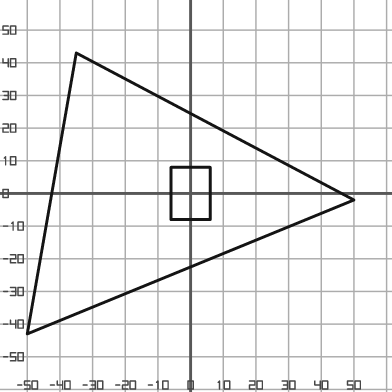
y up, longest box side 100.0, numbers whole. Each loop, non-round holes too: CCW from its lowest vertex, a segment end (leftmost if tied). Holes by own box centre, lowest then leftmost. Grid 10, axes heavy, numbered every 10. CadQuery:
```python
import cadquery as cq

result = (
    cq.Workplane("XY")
    .moveTo(-50.0, -43.0)
    .lineTo(50.0, -2.0)
    .lineTo(-35.0, 43.0)
    .close()
    .moveTo(-6.0, -8.0)
    .lineTo(6.0, -8.0)
    .lineTo(6.0, 8.0)
    .lineTo(-6.0, 8.0)
    .close()
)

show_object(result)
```